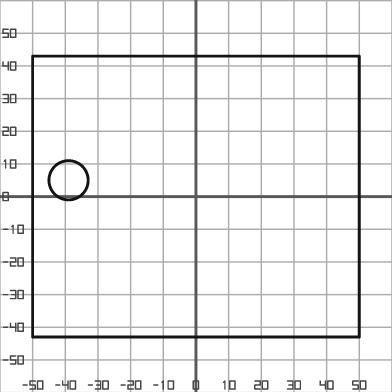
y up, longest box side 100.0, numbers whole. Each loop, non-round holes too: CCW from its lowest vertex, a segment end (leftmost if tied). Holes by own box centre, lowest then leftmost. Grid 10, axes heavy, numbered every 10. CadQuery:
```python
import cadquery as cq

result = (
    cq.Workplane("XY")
    .moveTo(-50.0, -43.0)
    .lineTo(50.0, -43.0)
    .lineTo(50.0, 43.0)
    .lineTo(-50.0, 43.0)
    .close()
    .moveTo(-39.0, 5.0)
    .circle(6.0)
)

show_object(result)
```